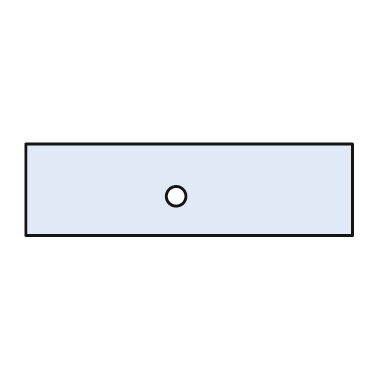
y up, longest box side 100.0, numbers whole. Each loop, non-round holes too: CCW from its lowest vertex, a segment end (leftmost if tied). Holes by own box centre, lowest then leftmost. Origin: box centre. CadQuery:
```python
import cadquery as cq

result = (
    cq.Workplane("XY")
    .moveTo(-50.0, -14.0)
    .lineTo(50.0, -14.0)
    .lineTo(50.0, 14.0)
    .lineTo(-50.0, 14.0)
    .close()
    .moveTo(-4.0, -2.0)
    .circle(3.0)
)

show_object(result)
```